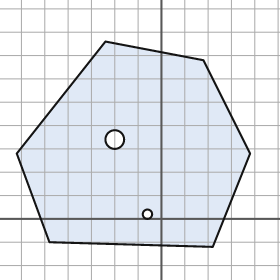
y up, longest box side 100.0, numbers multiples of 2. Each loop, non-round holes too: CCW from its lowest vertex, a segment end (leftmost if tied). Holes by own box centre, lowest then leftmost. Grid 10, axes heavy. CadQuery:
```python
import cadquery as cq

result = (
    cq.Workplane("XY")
    .moveTo(22.0, -12.0)
    .lineTo(38.0, 28.0)
    .lineTo(18.0, 68.0)
    .lineTo(-24.0, 76.0)
    .lineTo(-62.0, 28.0)
    .lineTo(-48.0, -10.0)
    .close()
    .moveTo(-6.0, 2.0)
    .circle(2.0)
    .moveTo(-20.0, 34.0)
    .circle(4.0)
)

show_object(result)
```